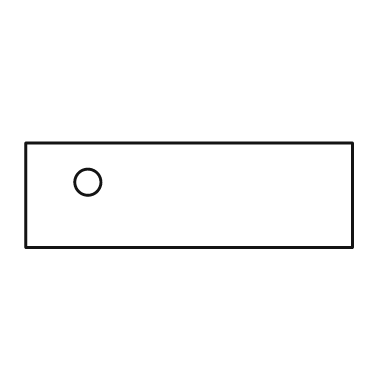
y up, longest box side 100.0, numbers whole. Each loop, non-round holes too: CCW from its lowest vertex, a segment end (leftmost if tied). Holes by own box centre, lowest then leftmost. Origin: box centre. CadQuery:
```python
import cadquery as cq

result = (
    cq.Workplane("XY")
    .moveTo(-50.0, -16.0)
    .lineTo(50.0, -16.0)
    .lineTo(50.0, 16.0)
    .lineTo(-50.0, 16.0)
    .close()
    .moveTo(-31.0, 4.0)
    .circle(4.0)
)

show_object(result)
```